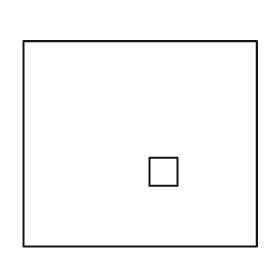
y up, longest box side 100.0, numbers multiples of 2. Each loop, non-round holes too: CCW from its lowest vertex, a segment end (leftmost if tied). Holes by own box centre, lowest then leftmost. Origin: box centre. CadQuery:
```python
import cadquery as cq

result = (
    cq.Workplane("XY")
    .moveTo(-50.0, -44.0)
    .lineTo(50.0, -44.0)
    .lineTo(50.0, 44.0)
    .lineTo(-50.0, 44.0)
    .close()
    .moveTo(4.0, -18.0)
    .lineTo(16.0, -18.0)
    .lineTo(16.0, -6.0)
    .lineTo(4.0, -6.0)
    .close()
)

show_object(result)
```